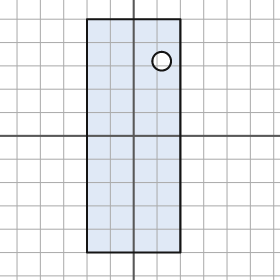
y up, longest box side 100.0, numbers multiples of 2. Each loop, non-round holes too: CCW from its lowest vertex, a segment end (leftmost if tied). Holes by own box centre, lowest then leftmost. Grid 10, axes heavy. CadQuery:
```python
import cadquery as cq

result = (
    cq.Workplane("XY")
    .moveTo(-20.0, -50.0)
    .lineTo(20.0, -50.0)
    .lineTo(20.0, 50.0)
    .lineTo(-20.0, 50.0)
    .close()
    .moveTo(12.0, 32.0)
    .circle(4.0)
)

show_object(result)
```